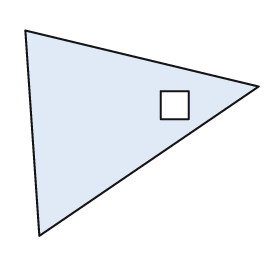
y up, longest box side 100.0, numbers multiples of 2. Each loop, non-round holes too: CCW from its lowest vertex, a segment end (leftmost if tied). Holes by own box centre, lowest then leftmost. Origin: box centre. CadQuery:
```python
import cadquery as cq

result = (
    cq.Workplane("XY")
    .moveTo(-44.0, -44.0)
    .lineTo(50.0, 20.0)
    .lineTo(-50.0, 44.0)
    .close()
    .moveTo(8.0, 6.0)
    .lineTo(20.0, 6.0)
    .lineTo(20.0, 18.0)
    .lineTo(8.0, 18.0)
    .close()
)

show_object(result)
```